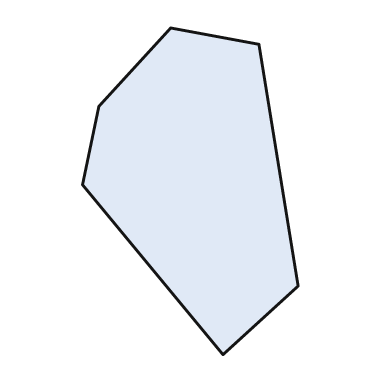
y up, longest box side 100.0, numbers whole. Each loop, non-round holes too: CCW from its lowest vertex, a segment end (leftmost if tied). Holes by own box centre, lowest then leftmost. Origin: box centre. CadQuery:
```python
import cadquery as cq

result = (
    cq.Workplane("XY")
    .moveTo(10.0, -50.0)
    .lineTo(33.0, -29.0)
    .lineTo(21.0, 45.0)
    .lineTo(-6.0, 50.0)
    .lineTo(-28.0, 26.0)
    .lineTo(-33.0, 2.0)
    .close()
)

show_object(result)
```